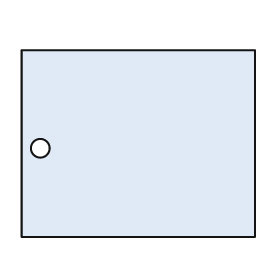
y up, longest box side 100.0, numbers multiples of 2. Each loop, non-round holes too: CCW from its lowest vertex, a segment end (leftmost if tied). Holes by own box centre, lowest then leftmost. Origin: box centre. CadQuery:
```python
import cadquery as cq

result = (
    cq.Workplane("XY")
    .moveTo(-50.0, -40.0)
    .lineTo(50.0, -40.0)
    .lineTo(50.0, 40.0)
    .lineTo(-50.0, 40.0)
    .close()
    .moveTo(-42.0, -2.0)
    .circle(4.0)
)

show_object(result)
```